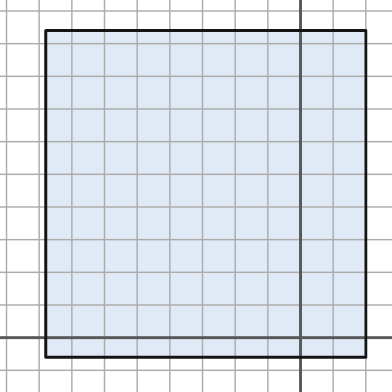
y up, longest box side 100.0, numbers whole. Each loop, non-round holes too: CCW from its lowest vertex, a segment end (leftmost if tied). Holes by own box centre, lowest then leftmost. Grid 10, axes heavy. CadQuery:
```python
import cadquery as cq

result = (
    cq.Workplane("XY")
    .moveTo(-78.0, -6.0)
    .lineTo(20.0, -6.0)
    .lineTo(20.0, 94.0)
    .lineTo(-78.0, 94.0)
    .close()
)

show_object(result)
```